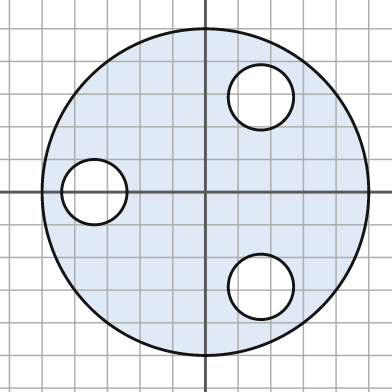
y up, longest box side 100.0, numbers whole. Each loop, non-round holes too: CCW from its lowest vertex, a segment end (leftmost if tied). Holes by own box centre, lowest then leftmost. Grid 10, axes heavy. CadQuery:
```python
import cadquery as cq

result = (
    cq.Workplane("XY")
    .moveTo(0.0, 0.0)
    .circle(50.0)
    .moveTo(17.0, -29.0)
    .circle(10.0)
    .moveTo(-34.0, 0.0)
    .circle(10.0)
    .moveTo(17.0, 29.0)
    .circle(10.0)
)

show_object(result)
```